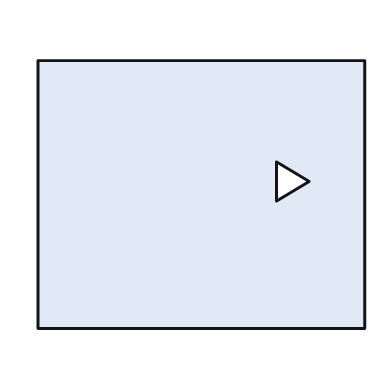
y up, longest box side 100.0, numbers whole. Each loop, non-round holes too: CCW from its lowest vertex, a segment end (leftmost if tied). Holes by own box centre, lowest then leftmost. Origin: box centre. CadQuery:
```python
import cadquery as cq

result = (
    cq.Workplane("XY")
    .moveTo(-50.0, -41.0)
    .lineTo(50.0, -41.0)
    .lineTo(50.0, 41.0)
    .lineTo(-50.0, 41.0)
    .close()
    .moveTo(23.0, -2.0)
    .lineTo(33.0, 4.0)
    .lineTo(23.0, 10.0)
    .close()
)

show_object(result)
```